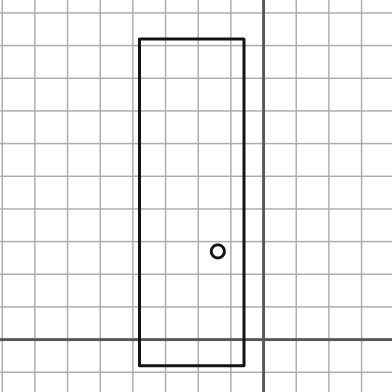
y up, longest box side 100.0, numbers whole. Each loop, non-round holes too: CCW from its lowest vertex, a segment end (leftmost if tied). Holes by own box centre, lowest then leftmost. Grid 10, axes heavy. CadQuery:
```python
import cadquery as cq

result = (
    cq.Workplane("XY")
    .moveTo(-38.0, -8.0)
    .lineTo(-6.0, -8.0)
    .lineTo(-6.0, 92.0)
    .lineTo(-38.0, 92.0)
    .close()
    .moveTo(-14.0, 27.0)
    .circle(2.0)
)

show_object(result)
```